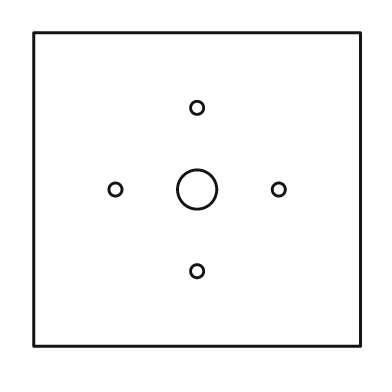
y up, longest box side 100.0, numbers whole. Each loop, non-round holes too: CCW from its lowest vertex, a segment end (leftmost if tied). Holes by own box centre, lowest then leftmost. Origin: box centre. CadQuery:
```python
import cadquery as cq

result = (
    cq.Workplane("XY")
    .moveTo(-50.0, -48.0)
    .lineTo(50.0, -48.0)
    .lineTo(50.0, 48.0)
    .lineTo(-50.0, 48.0)
    .close()
    .moveTo(0.0, -25.0)
    .circle(2.0)
    .moveTo(-25.0, 0.0)
    .circle(2.0)
    .moveTo(0.0, 0.0)
    .circle(6.0)
    .moveTo(25.0, 0.0)
    .circle(2.0)
    .moveTo(0.0, 25.0)
    .circle(2.0)
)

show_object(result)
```